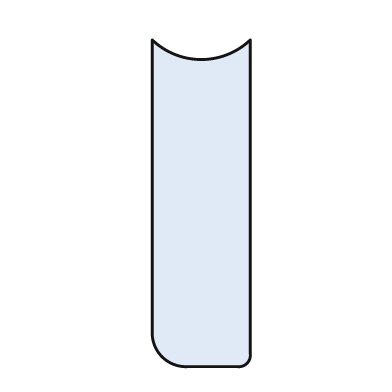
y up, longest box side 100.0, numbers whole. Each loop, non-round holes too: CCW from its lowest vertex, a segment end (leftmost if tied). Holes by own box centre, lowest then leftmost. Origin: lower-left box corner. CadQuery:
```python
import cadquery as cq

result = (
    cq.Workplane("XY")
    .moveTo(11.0, 0.0)
    .lineTo(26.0, 0.0)
    .threePointArc((29.0, 1.0), (30.0, 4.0))
    .lineTo(30.0, 100.0)
    .threePointArc((15.0, 94.0), (0.0, 100.0))
    .lineTo(0.0, 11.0)
    .threePointArc((3.0, 3.0), (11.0, 0.0))
    .close()
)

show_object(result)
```